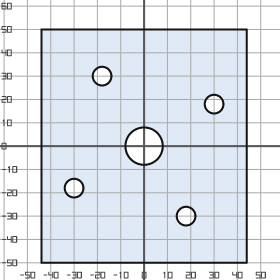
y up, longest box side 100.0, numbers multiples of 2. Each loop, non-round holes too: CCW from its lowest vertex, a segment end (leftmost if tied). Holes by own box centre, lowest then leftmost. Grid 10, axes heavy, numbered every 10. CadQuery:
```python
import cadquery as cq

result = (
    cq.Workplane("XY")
    .moveTo(-44.0, -50.0)
    .lineTo(44.0, -50.0)
    .lineTo(44.0, 50.0)
    .lineTo(-44.0, 50.0)
    .close()
    .moveTo(18.0, -30.0)
    .circle(4.0)
    .moveTo(-30.0, -18.0)
    .circle(4.0)
    .moveTo(0.0, 0.0)
    .circle(8.0)
    .moveTo(30.0, 18.0)
    .circle(4.0)
    .moveTo(-18.0, 30.0)
    .circle(4.0)
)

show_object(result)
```